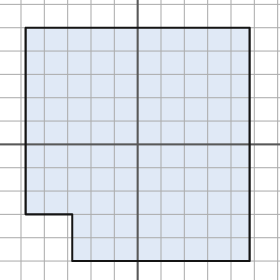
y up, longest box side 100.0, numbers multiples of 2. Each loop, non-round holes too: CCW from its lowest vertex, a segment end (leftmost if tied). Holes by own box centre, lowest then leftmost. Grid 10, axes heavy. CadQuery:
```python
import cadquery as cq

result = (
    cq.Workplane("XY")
    .moveTo(-28.0, -50.0)
    .lineTo(48.0, -50.0)
    .lineTo(48.0, 50.0)
    .lineTo(-48.0, 50.0)
    .lineTo(-48.0, -30.0)
    .lineTo(-28.0, -30.0)
    .close()
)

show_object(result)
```